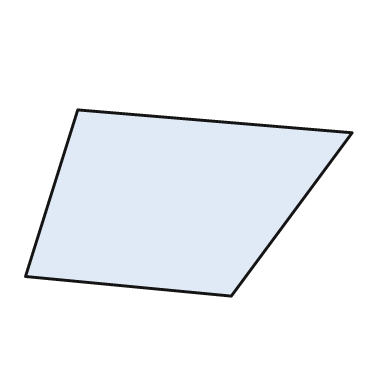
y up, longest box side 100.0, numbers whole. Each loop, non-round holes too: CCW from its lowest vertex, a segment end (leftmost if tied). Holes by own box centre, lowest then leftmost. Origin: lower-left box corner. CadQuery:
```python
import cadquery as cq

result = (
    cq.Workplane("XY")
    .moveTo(63.0, 0.0)
    .lineTo(100.0, 50.0)
    .lineTo(16.0, 57.0)
    .lineTo(0.0, 6.0)
    .close()
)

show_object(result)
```